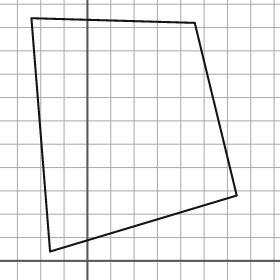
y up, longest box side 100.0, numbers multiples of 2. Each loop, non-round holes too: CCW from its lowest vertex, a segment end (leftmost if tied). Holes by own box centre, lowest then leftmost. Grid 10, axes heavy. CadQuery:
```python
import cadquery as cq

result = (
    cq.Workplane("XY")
    .moveTo(-16.0, 4.0)
    .lineTo(64.0, 28.0)
    .lineTo(46.0, 102.0)
    .lineTo(-24.0, 104.0)
    .close()
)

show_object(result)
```